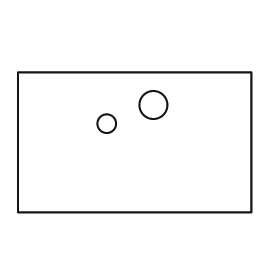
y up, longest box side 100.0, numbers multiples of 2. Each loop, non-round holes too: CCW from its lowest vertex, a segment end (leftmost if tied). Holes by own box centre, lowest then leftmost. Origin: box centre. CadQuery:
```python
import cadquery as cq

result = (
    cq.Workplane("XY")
    .moveTo(-50.0, -30.0)
    .lineTo(50.0, -30.0)
    .lineTo(50.0, 30.0)
    .lineTo(-50.0, 30.0)
    .close()
    .moveTo(-12.0, 8.0)
    .circle(4.0)
    .moveTo(8.0, 16.0)
    .circle(6.0)
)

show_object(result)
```